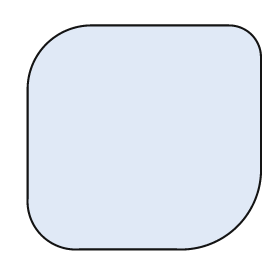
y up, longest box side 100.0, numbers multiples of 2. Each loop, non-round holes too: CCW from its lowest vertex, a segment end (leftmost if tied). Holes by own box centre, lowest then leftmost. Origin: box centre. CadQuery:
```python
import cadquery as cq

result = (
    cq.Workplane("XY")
    .moveTo(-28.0, -48.0)
    .lineTo(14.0, -48.0)
    .threePointArc((40.0, -38.0), (50.0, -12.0))
    .lineTo(50.0, 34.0)
    .threePointArc((46.0, 44.0), (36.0, 48.0))
    .lineTo(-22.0, 48.0)
    .threePointArc((-42.0, 40.0), (-50.0, 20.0))
    .lineTo(-50.0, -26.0)
    .threePointArc((-44.0, -42.0), (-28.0, -48.0))
    .close()
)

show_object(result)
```